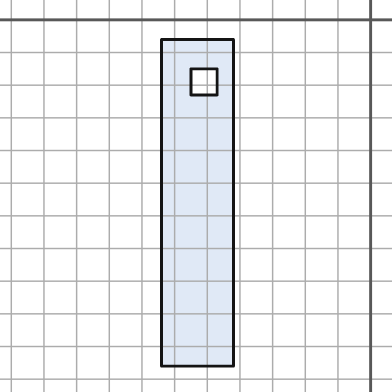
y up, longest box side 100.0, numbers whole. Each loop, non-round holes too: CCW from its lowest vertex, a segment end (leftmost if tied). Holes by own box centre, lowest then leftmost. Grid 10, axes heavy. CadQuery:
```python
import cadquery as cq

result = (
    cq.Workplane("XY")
    .moveTo(-64.0, -106.0)
    .lineTo(-42.0, -106.0)
    .lineTo(-42.0, -6.0)
    .lineTo(-64.0, -6.0)
    .close()
    .moveTo(-55.0, -23.0)
    .lineTo(-47.0, -23.0)
    .lineTo(-47.0, -15.0)
    .lineTo(-55.0, -15.0)
    .close()
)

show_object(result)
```